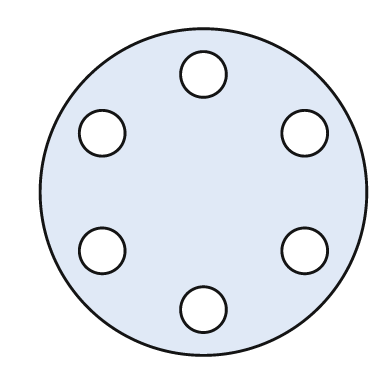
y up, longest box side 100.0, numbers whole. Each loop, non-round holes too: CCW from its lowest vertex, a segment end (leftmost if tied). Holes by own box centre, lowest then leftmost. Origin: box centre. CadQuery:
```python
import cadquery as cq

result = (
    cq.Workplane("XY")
    .moveTo(0.0, 0.0)
    .circle(50.0)
    .moveTo(0.0, -36.0)
    .circle(7.0)
    .moveTo(-31.0, -18.0)
    .circle(7.0)
    .moveTo(31.0, -18.0)
    .circle(7.0)
    .moveTo(-31.0, 18.0)
    .circle(7.0)
    .moveTo(31.0, 18.0)
    .circle(7.0)
    .moveTo(0.0, 36.0)
    .circle(7.0)
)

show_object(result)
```